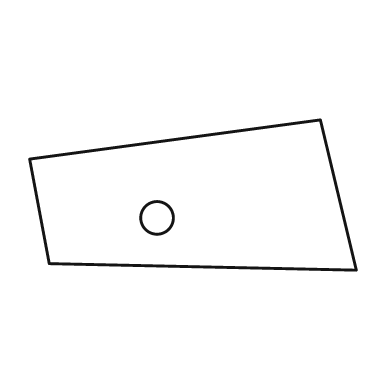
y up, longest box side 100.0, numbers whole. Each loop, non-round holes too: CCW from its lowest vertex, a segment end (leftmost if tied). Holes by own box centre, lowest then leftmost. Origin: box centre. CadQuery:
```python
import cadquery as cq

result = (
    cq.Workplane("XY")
    .moveTo(50.0, -23.0)
    .lineTo(39.0, 23.0)
    .lineTo(-50.0, 11.0)
    .lineTo(-44.0, -21.0)
    .close()
    .moveTo(-11.0, -7.0)
    .circle(5.0)
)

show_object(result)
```